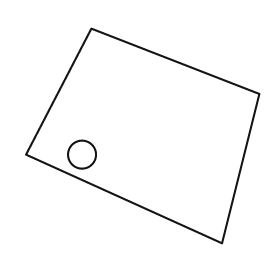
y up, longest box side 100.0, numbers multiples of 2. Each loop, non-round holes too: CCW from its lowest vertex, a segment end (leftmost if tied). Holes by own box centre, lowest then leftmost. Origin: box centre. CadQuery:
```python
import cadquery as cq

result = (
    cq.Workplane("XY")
    .moveTo(34.0, -46.0)
    .lineTo(50.0, 18.0)
    .lineTo(-22.0, 46.0)
    .lineTo(-50.0, -8.0)
    .close()
    .moveTo(-26.0, -8.0)
    .circle(6.0)
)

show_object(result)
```